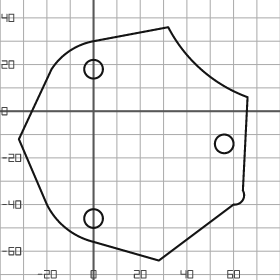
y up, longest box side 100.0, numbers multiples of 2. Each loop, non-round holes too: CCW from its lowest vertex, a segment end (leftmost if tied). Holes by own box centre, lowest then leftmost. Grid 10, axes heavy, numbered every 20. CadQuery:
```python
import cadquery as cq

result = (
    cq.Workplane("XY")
    .moveTo(28.0, -64.0)
    .lineTo(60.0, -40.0)
    .threePointArc((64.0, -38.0), (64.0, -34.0))
    .lineTo(66.0, 6.0)
    .threePointArc((46.0, 18.0), (32.0, 36.0))
    .lineTo(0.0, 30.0)
    .threePointArc((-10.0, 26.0), (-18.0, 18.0))
    .lineTo(-32.0, -12.0)
    .lineTo(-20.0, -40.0)
    .threePointArc((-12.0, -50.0), (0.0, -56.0))
    .close()
    .moveTo(0.0, -46.0)
    .circle(4.0)
    .moveTo(56.0, -14.0)
    .circle(4.0)
    .moveTo(0.0, 18.0)
    .circle(4.0)
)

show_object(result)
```